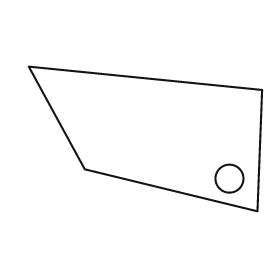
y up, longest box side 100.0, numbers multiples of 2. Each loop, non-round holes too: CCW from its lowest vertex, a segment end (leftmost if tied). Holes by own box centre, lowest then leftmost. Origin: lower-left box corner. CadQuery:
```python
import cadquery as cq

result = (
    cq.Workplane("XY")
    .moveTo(98.0, 0.0)
    .lineTo(100.0, 52.0)
    .lineTo(0.0, 62.0)
    .lineTo(24.0, 18.0)
    .close()
    .moveTo(86.0, 14.0)
    .circle(6.0)
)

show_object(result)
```